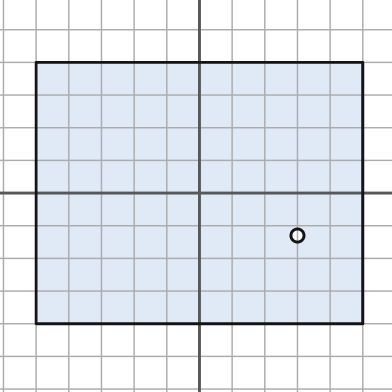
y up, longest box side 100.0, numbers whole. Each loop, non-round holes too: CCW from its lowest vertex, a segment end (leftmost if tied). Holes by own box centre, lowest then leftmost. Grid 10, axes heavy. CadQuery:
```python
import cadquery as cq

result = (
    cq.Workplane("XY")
    .moveTo(-50.0, -40.0)
    .lineTo(50.0, -40.0)
    .lineTo(50.0, 40.0)
    .lineTo(-50.0, 40.0)
    .close()
    .moveTo(30.0, -13.0)
    .circle(2.0)
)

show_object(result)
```